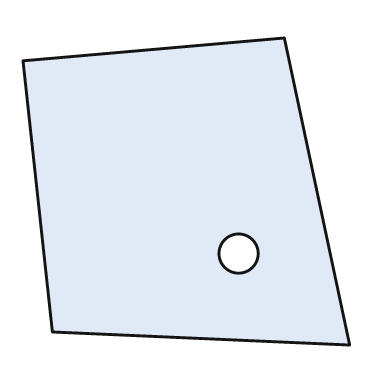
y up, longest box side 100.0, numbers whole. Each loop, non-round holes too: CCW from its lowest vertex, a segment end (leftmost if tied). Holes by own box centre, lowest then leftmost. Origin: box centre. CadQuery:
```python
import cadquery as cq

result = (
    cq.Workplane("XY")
    .moveTo(50.0, -47.0)
    .lineTo(30.0, 47.0)
    .lineTo(-50.0, 40.0)
    .lineTo(-41.0, -43.0)
    .close()
    .moveTo(16.0, -19.0)
    .circle(6.0)
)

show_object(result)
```